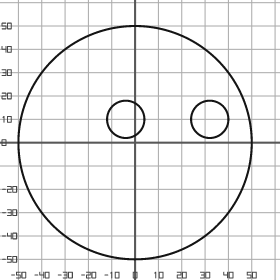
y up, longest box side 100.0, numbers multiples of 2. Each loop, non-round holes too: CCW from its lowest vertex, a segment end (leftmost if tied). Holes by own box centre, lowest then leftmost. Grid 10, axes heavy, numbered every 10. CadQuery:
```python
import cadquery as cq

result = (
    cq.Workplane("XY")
    .moveTo(0.0, 0.0)
    .circle(50.0)
    .moveTo(-4.0, 10.0)
    .circle(8.0)
    .moveTo(32.0, 10.0)
    .circle(8.0)
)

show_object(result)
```